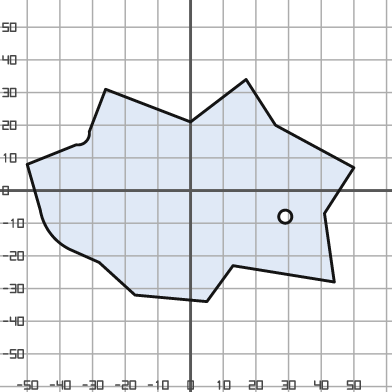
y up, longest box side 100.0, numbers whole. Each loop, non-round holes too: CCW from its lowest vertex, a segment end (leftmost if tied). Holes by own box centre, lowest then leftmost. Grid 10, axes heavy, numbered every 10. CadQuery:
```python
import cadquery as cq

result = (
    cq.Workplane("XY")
    .moveTo(5.0, -34.0)
    .lineTo(13.0, -23.0)
    .lineTo(44.0, -28.0)
    .lineTo(41.0, -7.0)
    .lineTo(50.0, 7.0)
    .lineTo(26.0, 20.0)
    .lineTo(17.0, 34.0)
    .lineTo(0.0, 21.0)
    .lineTo(-26.0, 31.0)
    .lineTo(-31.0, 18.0)
    .threePointArc((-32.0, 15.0), (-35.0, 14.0))
    .lineTo(-50.0, 8.0)
    .lineTo(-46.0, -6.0)
    .threePointArc((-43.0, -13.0), (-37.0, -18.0))
    .lineTo(-28.0, -22.0)
    .lineTo(-17.0, -32.0)
    .close()
    .moveTo(29.0, -8.0)
    .circle(2.0)
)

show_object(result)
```